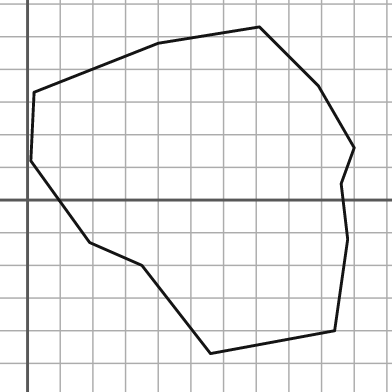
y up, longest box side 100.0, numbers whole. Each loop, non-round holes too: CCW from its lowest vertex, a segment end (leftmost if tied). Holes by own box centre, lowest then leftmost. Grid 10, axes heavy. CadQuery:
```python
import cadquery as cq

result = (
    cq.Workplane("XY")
    .moveTo(56.0, -47.0)
    .lineTo(94.0, -40.0)
    .lineTo(98.0, -12.0)
    .lineTo(96.0, 5.0)
    .lineTo(100.0, 16.0)
    .lineTo(89.0, 35.0)
    .lineTo(71.0, 53.0)
    .lineTo(40.0, 48.0)
    .lineTo(2.0, 33.0)
    .lineTo(1.0, 12.0)
    .lineTo(19.0, -13.0)
    .lineTo(35.0, -20.0)
    .close()
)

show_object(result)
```